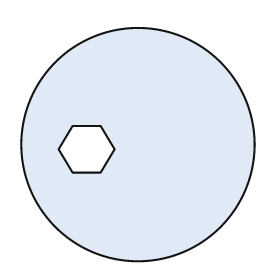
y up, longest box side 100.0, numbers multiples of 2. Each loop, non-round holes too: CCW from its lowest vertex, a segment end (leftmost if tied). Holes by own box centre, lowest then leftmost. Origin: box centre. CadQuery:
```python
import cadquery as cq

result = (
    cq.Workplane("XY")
    .moveTo(0.0, 0.0)
    .circle(50.0)
    .moveTo(-28.0, -12.0)
    .lineTo(-16.0, -12.0)
    .lineTo(-10.0, -2.0)
    .lineTo(-16.0, 8.0)
    .lineTo(-28.0, 8.0)
    .lineTo(-34.0, -2.0)
    .close()
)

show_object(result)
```